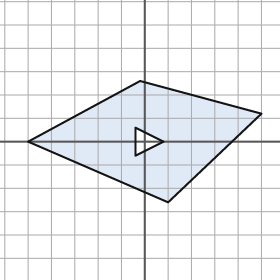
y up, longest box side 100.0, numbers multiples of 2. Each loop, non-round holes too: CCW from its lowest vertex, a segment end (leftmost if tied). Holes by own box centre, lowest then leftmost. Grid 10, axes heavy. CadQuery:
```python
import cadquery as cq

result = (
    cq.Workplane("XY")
    .moveTo(10.0, -26.0)
    .lineTo(50.0, 12.0)
    .lineTo(-2.0, 26.0)
    .lineTo(-50.0, 0.0)
    .close()
    .moveTo(-4.0, -6.0)
    .lineTo(8.0, 0.0)
    .lineTo(-4.0, 6.0)
    .close()
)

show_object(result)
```